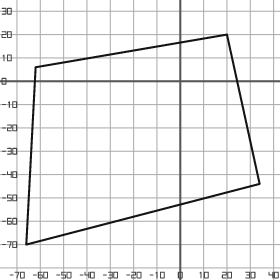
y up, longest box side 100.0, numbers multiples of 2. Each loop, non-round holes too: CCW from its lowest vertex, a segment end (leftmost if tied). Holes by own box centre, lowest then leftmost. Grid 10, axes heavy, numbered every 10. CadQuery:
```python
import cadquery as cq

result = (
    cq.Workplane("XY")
    .moveTo(-66.0, -70.0)
    .lineTo(34.0, -44.0)
    .lineTo(20.0, 20.0)
    .lineTo(-62.0, 6.0)
    .close()
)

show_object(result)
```